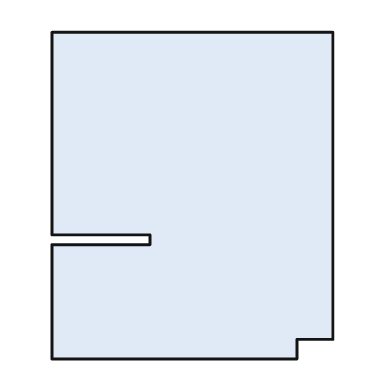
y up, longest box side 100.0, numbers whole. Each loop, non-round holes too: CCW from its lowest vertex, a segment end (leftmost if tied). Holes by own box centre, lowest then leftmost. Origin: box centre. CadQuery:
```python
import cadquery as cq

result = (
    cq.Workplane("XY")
    .moveTo(-43.0, -50.0)
    .lineTo(32.0, -50.0)
    .lineTo(32.0, -44.0)
    .lineTo(43.0, -44.0)
    .lineTo(43.0, 50.0)
    .lineTo(-43.0, 50.0)
    .lineTo(-43.0, -12.0)
    .lineTo(-13.0, -12.0)
    .lineTo(-13.0, -15.0)
    .lineTo(-43.0, -15.0)
    .close()
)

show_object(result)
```